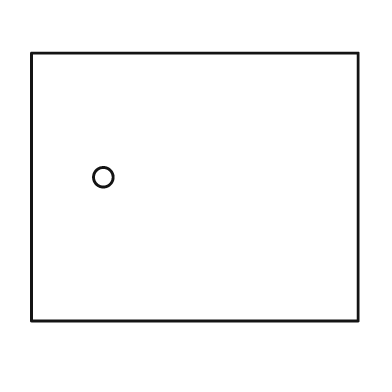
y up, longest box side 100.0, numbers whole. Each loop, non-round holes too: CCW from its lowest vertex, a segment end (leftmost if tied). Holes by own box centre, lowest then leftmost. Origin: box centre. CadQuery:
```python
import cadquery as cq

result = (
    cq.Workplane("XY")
    .moveTo(-50.0, -41.0)
    .lineTo(50.0, -41.0)
    .lineTo(50.0, 41.0)
    .lineTo(-50.0, 41.0)
    .close()
    .moveTo(-28.0, 3.0)
    .circle(3.0)
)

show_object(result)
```